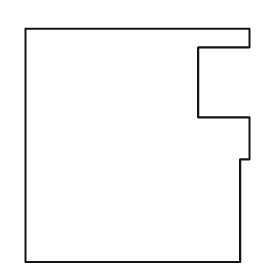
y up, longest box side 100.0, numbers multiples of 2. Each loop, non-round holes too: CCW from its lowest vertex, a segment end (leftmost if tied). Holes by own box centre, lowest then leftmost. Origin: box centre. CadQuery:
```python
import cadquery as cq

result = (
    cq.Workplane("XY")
    .moveTo(-48.0, -50.0)
    .lineTo(44.0, -50.0)
    .lineTo(44.0, -6.0)
    .lineTo(48.0, -6.0)
    .lineTo(48.0, 12.0)
    .lineTo(26.0, 12.0)
    .lineTo(26.0, 42.0)
    .lineTo(48.0, 42.0)
    .lineTo(48.0, 50.0)
    .lineTo(-48.0, 50.0)
    .close()
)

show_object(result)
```